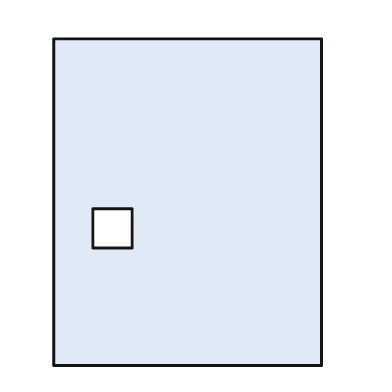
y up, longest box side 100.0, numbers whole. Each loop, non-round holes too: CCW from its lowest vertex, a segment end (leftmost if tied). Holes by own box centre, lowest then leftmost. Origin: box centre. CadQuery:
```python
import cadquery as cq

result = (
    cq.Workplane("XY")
    .moveTo(-41.0, -50.0)
    .lineTo(41.0, -50.0)
    .lineTo(41.0, 50.0)
    .lineTo(-41.0, 50.0)
    .close()
    .moveTo(-29.0, -14.0)
    .lineTo(-17.0, -14.0)
    .lineTo(-17.0, -2.0)
    .lineTo(-29.0, -2.0)
    .close()
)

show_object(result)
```